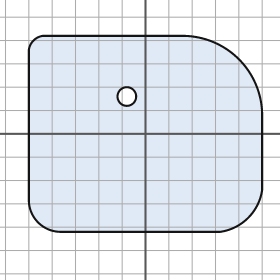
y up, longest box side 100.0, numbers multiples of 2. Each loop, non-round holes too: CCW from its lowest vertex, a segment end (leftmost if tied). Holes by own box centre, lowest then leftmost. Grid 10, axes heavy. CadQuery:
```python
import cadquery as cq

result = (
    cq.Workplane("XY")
    .moveTo(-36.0, -42.0)
    .lineTo(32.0, -42.0)
    .threePointArc((44.0, -36.0), (50.0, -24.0))
    .lineTo(50.0, 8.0)
    .threePointArc((40.0, 32.0), (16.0, 42.0))
    .lineTo(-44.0, 42.0)
    .threePointArc((-48.0, 40.0), (-50.0, 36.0))
    .lineTo(-50.0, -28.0)
    .threePointArc((-46.0, -38.0), (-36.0, -42.0))
    .close()
    .moveTo(-8.0, 16.0)
    .circle(4.0)
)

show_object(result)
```